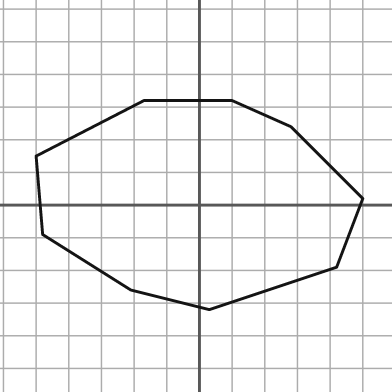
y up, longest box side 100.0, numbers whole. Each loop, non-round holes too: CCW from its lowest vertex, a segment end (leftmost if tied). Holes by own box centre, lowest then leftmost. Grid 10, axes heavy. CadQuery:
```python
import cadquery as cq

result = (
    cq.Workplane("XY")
    .moveTo(3.0, -32.0)
    .lineTo(42.0, -19.0)
    .lineTo(50.0, 2.0)
    .lineTo(28.0, 24.0)
    .lineTo(10.0, 32.0)
    .lineTo(-17.0, 32.0)
    .lineTo(-50.0, 15.0)
    .lineTo(-48.0, -9.0)
    .lineTo(-21.0, -26.0)
    .close()
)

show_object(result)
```